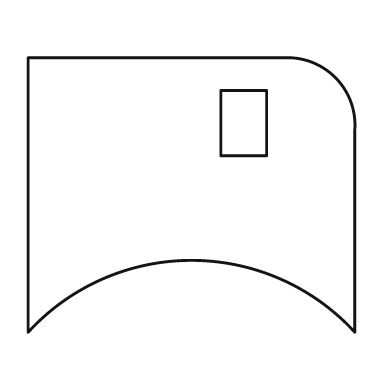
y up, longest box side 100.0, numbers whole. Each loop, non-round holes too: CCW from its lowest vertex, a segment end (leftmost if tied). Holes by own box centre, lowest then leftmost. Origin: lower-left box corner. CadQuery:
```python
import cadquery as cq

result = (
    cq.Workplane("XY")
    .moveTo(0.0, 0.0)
    .threePointArc((50.0, 22.0), (100.0, 0.0))
    .lineTo(100.0, 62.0)
    .threePointArc((94.0, 78.0), (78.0, 84.0))
    .lineTo(0.0, 84.0)
    .close()
    .moveTo(59.0, 54.0)
    .lineTo(73.0, 54.0)
    .lineTo(73.0, 74.0)
    .lineTo(59.0, 74.0)
    .close()
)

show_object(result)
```